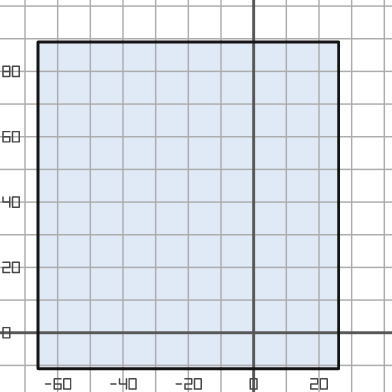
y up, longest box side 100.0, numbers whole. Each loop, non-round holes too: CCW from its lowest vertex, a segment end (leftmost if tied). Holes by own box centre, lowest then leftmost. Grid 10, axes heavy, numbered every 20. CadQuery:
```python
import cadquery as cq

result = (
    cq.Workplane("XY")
    .moveTo(-66.0, -11.0)
    .lineTo(26.0, -11.0)
    .lineTo(26.0, 89.0)
    .lineTo(-66.0, 89.0)
    .close()
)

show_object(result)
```